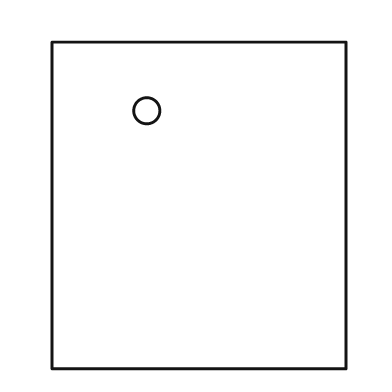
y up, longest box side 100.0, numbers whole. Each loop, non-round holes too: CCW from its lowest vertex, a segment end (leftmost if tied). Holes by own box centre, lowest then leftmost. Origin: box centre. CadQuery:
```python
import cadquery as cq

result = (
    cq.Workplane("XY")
    .moveTo(-45.0, -50.0)
    .lineTo(45.0, -50.0)
    .lineTo(45.0, 50.0)
    .lineTo(-45.0, 50.0)
    .close()
    .moveTo(-16.0, 29.0)
    .circle(4.0)
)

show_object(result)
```